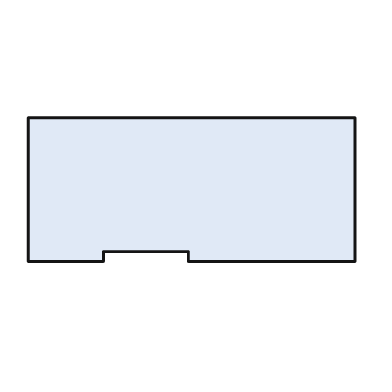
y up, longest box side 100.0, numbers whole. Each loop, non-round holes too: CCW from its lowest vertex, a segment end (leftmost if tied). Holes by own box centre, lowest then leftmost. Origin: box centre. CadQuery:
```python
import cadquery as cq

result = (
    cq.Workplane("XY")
    .moveTo(-50.0, -22.0)
    .lineTo(-27.0, -22.0)
    .lineTo(-27.0, -19.0)
    .lineTo(-1.0, -19.0)
    .lineTo(-1.0, -22.0)
    .lineTo(50.0, -22.0)
    .lineTo(50.0, 22.0)
    .lineTo(-50.0, 22.0)
    .close()
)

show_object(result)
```